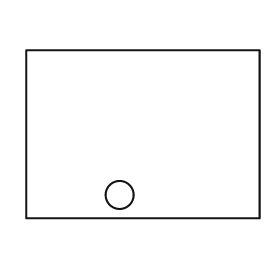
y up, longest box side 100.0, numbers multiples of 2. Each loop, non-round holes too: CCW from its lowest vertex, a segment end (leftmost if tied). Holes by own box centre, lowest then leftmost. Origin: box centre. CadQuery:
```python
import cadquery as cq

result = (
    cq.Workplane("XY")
    .moveTo(-50.0, -36.0)
    .lineTo(50.0, -36.0)
    .lineTo(50.0, 36.0)
    .lineTo(-50.0, 36.0)
    .close()
    .moveTo(-10.0, -26.0)
    .circle(6.0)
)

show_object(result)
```